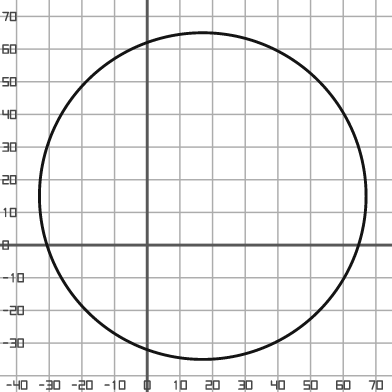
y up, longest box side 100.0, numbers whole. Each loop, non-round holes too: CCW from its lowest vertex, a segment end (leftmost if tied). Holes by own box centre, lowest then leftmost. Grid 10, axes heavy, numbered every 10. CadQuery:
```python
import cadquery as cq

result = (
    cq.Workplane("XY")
    .moveTo(17.0, 15.0)
    .circle(50.0)
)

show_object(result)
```